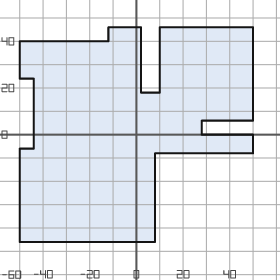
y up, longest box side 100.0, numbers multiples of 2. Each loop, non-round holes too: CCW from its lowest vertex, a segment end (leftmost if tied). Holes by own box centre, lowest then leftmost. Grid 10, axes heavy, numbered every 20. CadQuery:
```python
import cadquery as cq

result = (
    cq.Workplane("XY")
    .moveTo(-50.0, -46.0)
    .lineTo(8.0, -46.0)
    .lineTo(8.0, -8.0)
    .lineTo(50.0, -8.0)
    .lineTo(50.0, 0.0)
    .lineTo(28.0, 0.0)
    .lineTo(28.0, 6.0)
    .lineTo(50.0, 6.0)
    .lineTo(50.0, 46.0)
    .lineTo(10.0, 46.0)
    .lineTo(10.0, 18.0)
    .lineTo(2.0, 18.0)
    .lineTo(2.0, 46.0)
    .lineTo(-12.0, 46.0)
    .lineTo(-12.0, 40.0)
    .lineTo(-50.0, 40.0)
    .lineTo(-50.0, 24.0)
    .lineTo(-44.0, 24.0)
    .lineTo(-44.0, -6.0)
    .lineTo(-50.0, -6.0)
    .close()
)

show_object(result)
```